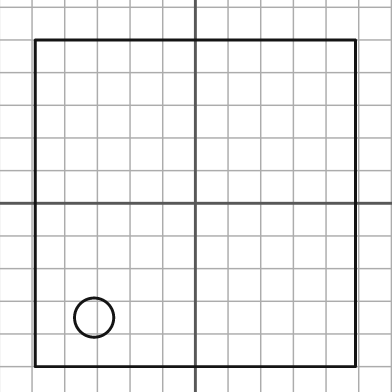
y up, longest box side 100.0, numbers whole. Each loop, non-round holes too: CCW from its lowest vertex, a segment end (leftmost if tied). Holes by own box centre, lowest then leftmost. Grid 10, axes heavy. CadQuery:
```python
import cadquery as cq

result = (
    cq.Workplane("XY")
    .moveTo(-49.0, -50.0)
    .lineTo(49.0, -50.0)
    .lineTo(49.0, 50.0)
    .lineTo(-49.0, 50.0)
    .close()
    .moveTo(-31.0, -35.0)
    .circle(6.0)
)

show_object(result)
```